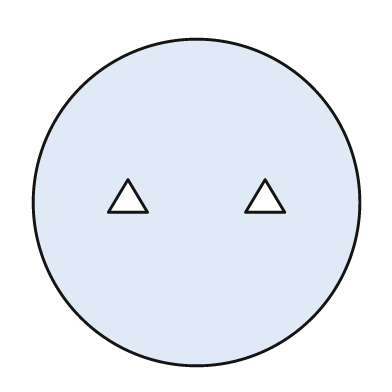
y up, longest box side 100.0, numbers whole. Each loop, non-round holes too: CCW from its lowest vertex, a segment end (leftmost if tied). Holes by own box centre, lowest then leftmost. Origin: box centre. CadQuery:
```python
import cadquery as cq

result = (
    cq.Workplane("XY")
    .moveTo(0.0, 0.0)
    .circle(50.0)
    .moveTo(-27.0, -3.0)
    .lineTo(-15.0, -3.0)
    .lineTo(-21.0, 7.0)
    .close()
    .moveTo(15.0, -3.0)
    .lineTo(27.0, -3.0)
    .lineTo(21.0, 7.0)
    .close()
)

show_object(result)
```